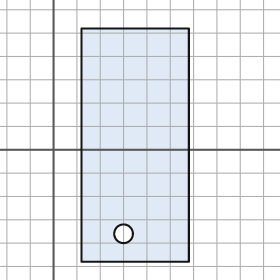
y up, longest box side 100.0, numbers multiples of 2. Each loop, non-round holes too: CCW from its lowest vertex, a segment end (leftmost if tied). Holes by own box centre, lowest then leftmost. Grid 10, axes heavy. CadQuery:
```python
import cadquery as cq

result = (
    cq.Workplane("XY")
    .moveTo(12.0, -48.0)
    .lineTo(58.0, -48.0)
    .lineTo(58.0, 52.0)
    .lineTo(12.0, 52.0)
    .close()
    .moveTo(30.0, -36.0)
    .circle(4.0)
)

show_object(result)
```